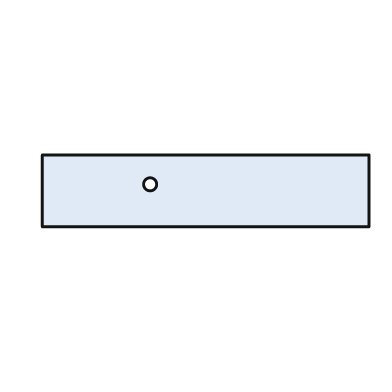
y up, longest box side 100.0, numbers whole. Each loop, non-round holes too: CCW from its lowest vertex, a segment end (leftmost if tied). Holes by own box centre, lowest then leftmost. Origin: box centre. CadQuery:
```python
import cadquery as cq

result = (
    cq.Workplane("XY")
    .moveTo(-50.0, -11.0)
    .lineTo(50.0, -11.0)
    .lineTo(50.0, 11.0)
    .lineTo(-50.0, 11.0)
    .close()
    .moveTo(-17.0, 2.0)
    .circle(2.0)
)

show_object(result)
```